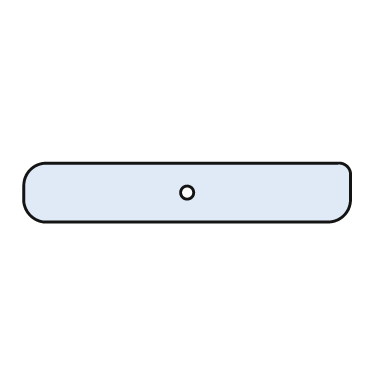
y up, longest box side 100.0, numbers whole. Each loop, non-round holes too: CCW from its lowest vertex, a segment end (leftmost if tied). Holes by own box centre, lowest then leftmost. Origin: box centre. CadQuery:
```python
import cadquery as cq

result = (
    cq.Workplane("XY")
    .moveTo(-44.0, -9.0)
    .lineTo(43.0, -9.0)
    .threePointArc((48.0, -7.0), (50.0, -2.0))
    .lineTo(50.0, 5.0)
    .threePointArc((49.0, 8.0), (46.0, 9.0))
    .lineTo(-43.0, 9.0)
    .threePointArc((-48.0, 7.0), (-50.0, 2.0))
    .lineTo(-50.0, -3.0)
    .threePointArc((-48.0, -7.0), (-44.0, -9.0))
    .close()
    .moveTo(0.0, 0.0)
    .circle(2.0)
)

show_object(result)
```